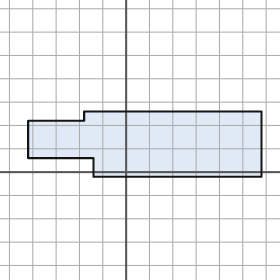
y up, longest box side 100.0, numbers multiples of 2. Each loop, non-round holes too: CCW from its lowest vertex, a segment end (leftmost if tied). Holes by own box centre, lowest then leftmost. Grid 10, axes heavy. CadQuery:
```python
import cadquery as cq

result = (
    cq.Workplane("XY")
    .moveTo(-14.0, -2.0)
    .lineTo(58.0, -2.0)
    .lineTo(58.0, 26.0)
    .lineTo(-18.0, 26.0)
    .lineTo(-18.0, 22.0)
    .lineTo(-42.0, 22.0)
    .lineTo(-42.0, 6.0)
    .lineTo(-14.0, 6.0)
    .close()
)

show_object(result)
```